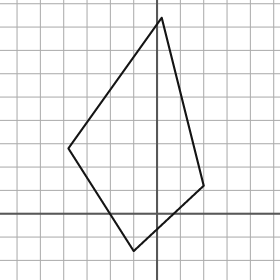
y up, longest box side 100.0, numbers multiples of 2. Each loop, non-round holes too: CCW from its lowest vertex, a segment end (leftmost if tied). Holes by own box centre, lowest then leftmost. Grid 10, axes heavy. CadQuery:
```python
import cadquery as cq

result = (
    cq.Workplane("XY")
    .moveTo(-10.0, -16.0)
    .lineTo(20.0, 12.0)
    .lineTo(2.0, 84.0)
    .lineTo(-38.0, 28.0)
    .close()
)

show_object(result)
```